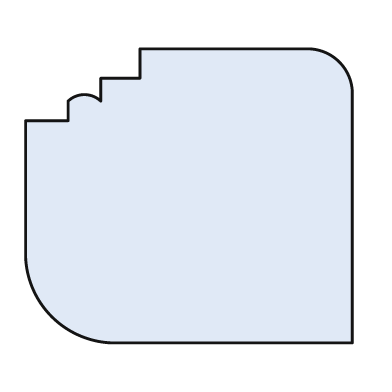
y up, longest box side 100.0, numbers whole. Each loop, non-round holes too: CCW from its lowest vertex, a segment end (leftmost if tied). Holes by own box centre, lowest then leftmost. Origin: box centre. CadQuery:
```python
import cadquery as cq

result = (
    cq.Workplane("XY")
    .moveTo(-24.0, -45.0)
    .lineTo(50.0, -45.0)
    .lineTo(50.0, 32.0)
    .threePointArc((46.0, 41.0), (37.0, 45.0))
    .lineTo(-15.0, 45.0)
    .lineTo(-15.0, 36.0)
    .lineTo(-27.0, 36.0)
    .lineTo(-27.0, 29.0)
    .threePointArc((-32.0, 31.0), (-37.0, 29.0))
    .lineTo(-37.0, 23.0)
    .lineTo(-50.0, 23.0)
    .lineTo(-50.0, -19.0)
    .threePointArc((-42.0, -37.0), (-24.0, -45.0))
    .close()
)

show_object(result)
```